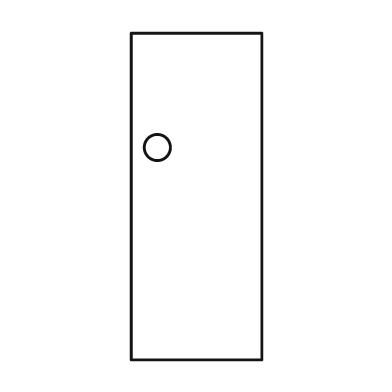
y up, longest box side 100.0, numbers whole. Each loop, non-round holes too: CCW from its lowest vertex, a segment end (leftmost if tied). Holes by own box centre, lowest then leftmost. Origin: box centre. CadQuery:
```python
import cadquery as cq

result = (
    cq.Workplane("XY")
    .moveTo(-20.0, -50.0)
    .lineTo(20.0, -50.0)
    .lineTo(20.0, 50.0)
    .lineTo(-20.0, 50.0)
    .close()
    .moveTo(-12.0, 15.0)
    .circle(4.0)
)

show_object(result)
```